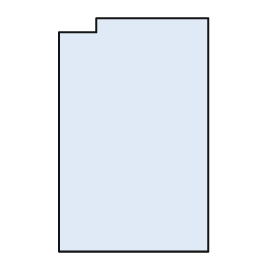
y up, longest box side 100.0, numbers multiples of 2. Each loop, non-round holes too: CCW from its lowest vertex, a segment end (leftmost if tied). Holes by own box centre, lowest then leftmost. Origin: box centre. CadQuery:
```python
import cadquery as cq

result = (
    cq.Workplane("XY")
    .moveTo(-32.0, -50.0)
    .lineTo(32.0, -50.0)
    .lineTo(32.0, 50.0)
    .lineTo(-16.0, 50.0)
    .lineTo(-16.0, 44.0)
    .lineTo(-32.0, 44.0)
    .close()
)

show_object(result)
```